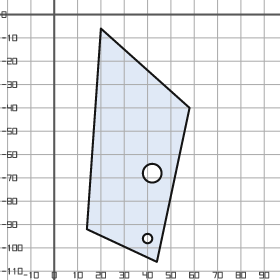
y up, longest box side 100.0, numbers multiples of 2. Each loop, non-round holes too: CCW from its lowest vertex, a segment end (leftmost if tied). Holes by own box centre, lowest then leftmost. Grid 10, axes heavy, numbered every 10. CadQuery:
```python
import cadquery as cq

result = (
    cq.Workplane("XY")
    .moveTo(44.0, -106.0)
    .lineTo(58.0, -40.0)
    .lineTo(20.0, -6.0)
    .lineTo(14.0, -92.0)
    .close()
    .moveTo(40.0, -96.0)
    .circle(2.0)
    .moveTo(42.0, -68.0)
    .circle(4.0)
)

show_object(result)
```